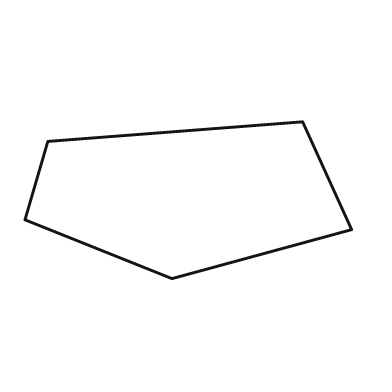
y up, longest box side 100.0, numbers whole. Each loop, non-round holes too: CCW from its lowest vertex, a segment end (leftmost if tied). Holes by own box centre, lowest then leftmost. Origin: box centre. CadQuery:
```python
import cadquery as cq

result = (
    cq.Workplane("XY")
    .moveTo(-5.0, -24.0)
    .lineTo(50.0, -9.0)
    .lineTo(35.0, 24.0)
    .lineTo(-43.0, 18.0)
    .lineTo(-50.0, -6.0)
    .close()
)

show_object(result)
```